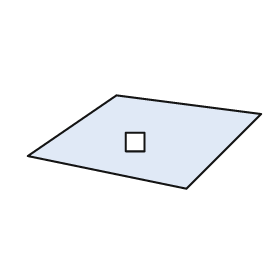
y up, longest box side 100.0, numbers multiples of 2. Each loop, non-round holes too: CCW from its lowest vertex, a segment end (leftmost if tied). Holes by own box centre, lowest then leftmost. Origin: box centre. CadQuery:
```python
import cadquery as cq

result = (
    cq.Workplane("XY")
    .moveTo(18.0, -20.0)
    .lineTo(50.0, 12.0)
    .lineTo(-12.0, 20.0)
    .lineTo(-50.0, -6.0)
    .close()
    .moveTo(-8.0, -4.0)
    .lineTo(0.0, -4.0)
    .lineTo(0.0, 4.0)
    .lineTo(-8.0, 4.0)
    .close()
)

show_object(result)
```